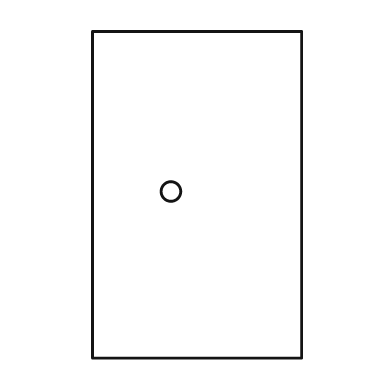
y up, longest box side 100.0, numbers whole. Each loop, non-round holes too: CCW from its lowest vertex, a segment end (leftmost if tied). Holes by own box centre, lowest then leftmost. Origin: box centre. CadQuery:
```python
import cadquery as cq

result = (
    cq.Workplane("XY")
    .moveTo(-32.0, -50.0)
    .lineTo(32.0, -50.0)
    .lineTo(32.0, 50.0)
    .lineTo(-32.0, 50.0)
    .close()
    .moveTo(-8.0, 1.0)
    .circle(3.0)
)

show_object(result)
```